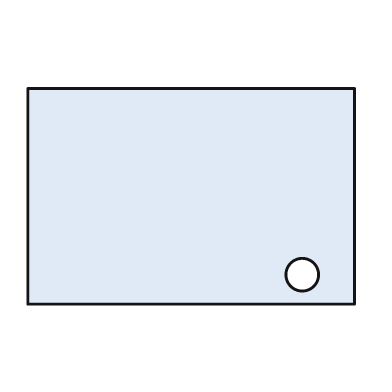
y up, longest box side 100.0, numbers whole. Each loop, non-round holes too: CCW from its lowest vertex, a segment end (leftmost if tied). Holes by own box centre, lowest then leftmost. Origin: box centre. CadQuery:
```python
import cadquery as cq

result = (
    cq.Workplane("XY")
    .moveTo(-50.0, -33.0)
    .lineTo(50.0, -33.0)
    .lineTo(50.0, 33.0)
    .lineTo(-50.0, 33.0)
    .close()
    .moveTo(34.0, -24.0)
    .circle(5.0)
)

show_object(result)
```